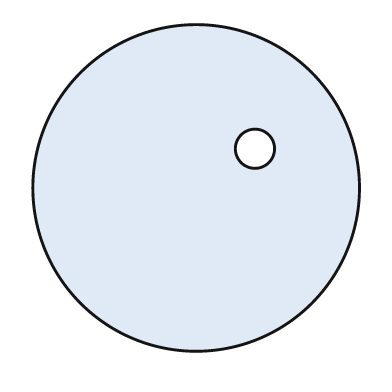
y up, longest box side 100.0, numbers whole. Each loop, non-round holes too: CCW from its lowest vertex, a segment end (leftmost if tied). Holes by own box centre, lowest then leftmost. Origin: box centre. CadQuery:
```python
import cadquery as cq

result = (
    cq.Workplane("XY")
    .moveTo(0.0, 0.0)
    .circle(50.0)
    .moveTo(18.0, 12.0)
    .circle(6.0)
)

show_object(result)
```